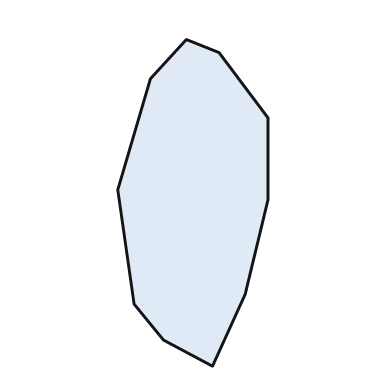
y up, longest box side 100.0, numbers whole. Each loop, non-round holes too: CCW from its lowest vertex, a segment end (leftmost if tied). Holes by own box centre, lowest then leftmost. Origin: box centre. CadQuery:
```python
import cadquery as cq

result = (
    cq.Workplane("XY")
    .moveTo(6.0, -50.0)
    .lineTo(16.0, -28.0)
    .lineTo(23.0, 1.0)
    .lineTo(23.0, 26.0)
    .lineTo(8.0, 46.0)
    .lineTo(-2.0, 50.0)
    .lineTo(-13.0, 38.0)
    .lineTo(-23.0, 4.0)
    .lineTo(-18.0, -31.0)
    .lineTo(-9.0, -42.0)
    .close()
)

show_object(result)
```